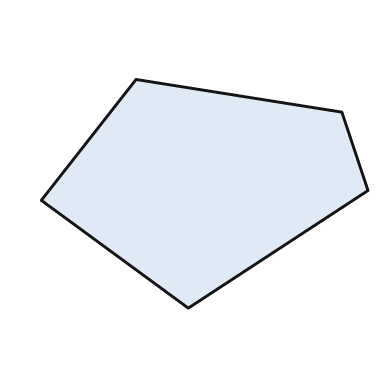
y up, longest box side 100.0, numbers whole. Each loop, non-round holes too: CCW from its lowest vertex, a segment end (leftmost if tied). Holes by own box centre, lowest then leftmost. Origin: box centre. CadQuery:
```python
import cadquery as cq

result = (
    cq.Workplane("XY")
    .moveTo(-5.0, -35.0)
    .lineTo(50.0, 1.0)
    .lineTo(42.0, 25.0)
    .lineTo(-21.0, 35.0)
    .lineTo(-50.0, -2.0)
    .close()
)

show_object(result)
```